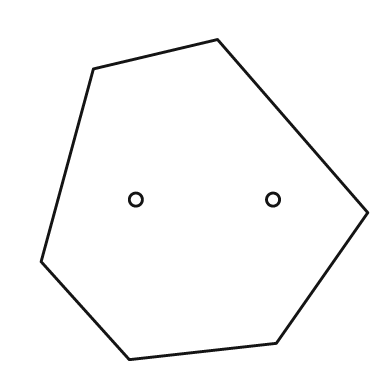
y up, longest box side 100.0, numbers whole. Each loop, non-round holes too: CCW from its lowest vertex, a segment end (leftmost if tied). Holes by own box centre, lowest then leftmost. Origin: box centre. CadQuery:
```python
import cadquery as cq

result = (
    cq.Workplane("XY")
    .moveTo(-23.0, -49.0)
    .lineTo(22.0, -44.0)
    .lineTo(50.0, -4.0)
    .lineTo(4.0, 49.0)
    .lineTo(-34.0, 40.0)
    .lineTo(-50.0, -19.0)
    .close()
    .moveTo(-21.0, 0.0)
    .circle(2.0)
    .moveTo(21.0, 0.0)
    .circle(2.0)
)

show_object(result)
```